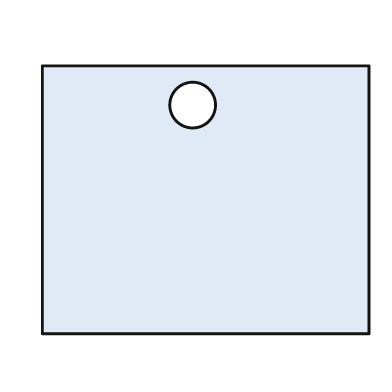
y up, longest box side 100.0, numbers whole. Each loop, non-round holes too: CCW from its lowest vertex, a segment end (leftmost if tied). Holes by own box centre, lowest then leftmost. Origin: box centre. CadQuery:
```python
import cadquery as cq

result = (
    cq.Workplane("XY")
    .moveTo(-50.0, -41.0)
    .lineTo(50.0, -41.0)
    .lineTo(50.0, 41.0)
    .lineTo(-50.0, 41.0)
    .close()
    .moveTo(-4.0, 29.0)
    .circle(7.0)
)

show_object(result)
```